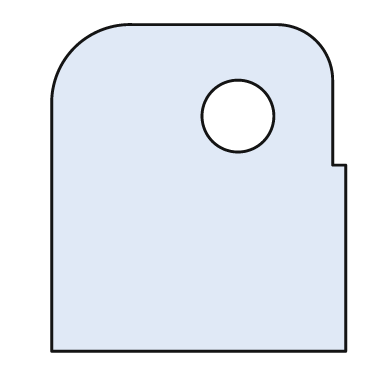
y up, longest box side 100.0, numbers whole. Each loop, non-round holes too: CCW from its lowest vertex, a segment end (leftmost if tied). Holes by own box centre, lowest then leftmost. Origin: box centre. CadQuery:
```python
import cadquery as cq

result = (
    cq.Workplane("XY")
    .moveTo(-45.0, -50.0)
    .lineTo(45.0, -50.0)
    .lineTo(45.0, 7.0)
    .lineTo(41.0, 7.0)
    .lineTo(41.0, 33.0)
    .threePointArc((36.0, 45.0), (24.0, 50.0))
    .lineTo(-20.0, 50.0)
    .threePointArc((-38.0, 43.0), (-45.0, 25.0))
    .close()
    .moveTo(12.0, 22.0)
    .circle(11.0)
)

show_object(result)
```